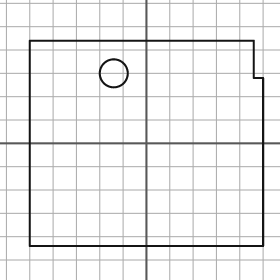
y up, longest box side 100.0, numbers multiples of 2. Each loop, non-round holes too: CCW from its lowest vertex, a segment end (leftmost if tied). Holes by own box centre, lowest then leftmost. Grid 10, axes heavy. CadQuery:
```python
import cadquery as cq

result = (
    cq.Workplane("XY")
    .moveTo(-50.0, -44.0)
    .lineTo(50.0, -44.0)
    .lineTo(50.0, 28.0)
    .lineTo(46.0, 28.0)
    .lineTo(46.0, 44.0)
    .lineTo(-50.0, 44.0)
    .close()
    .moveTo(-14.0, 30.0)
    .circle(6.0)
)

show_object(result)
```